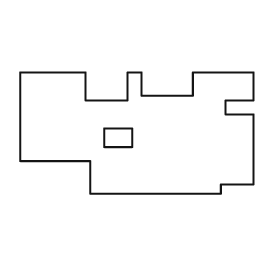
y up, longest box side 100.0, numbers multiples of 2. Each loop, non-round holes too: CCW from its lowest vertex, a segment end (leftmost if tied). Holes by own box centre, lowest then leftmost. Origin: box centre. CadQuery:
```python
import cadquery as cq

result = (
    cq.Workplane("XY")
    .moveTo(-20.0, -26.0)
    .lineTo(36.0, -26.0)
    .lineTo(36.0, -22.0)
    .lineTo(50.0, -22.0)
    .lineTo(50.0, 8.0)
    .lineTo(38.0, 8.0)
    .lineTo(38.0, 14.0)
    .lineTo(50.0, 14.0)
    .lineTo(50.0, 26.0)
    .lineTo(24.0, 26.0)
    .lineTo(24.0, 16.0)
    .lineTo(2.0, 16.0)
    .lineTo(2.0, 26.0)
    .lineTo(-4.0, 26.0)
    .lineTo(-4.0, 14.0)
    .lineTo(-22.0, 14.0)
    .lineTo(-22.0, 26.0)
    .lineTo(-50.0, 26.0)
    .lineTo(-50.0, -12.0)
    .lineTo(-20.0, -12.0)
    .close()
    .moveTo(-14.0, -6.0)
    .lineTo(-2.0, -6.0)
    .lineTo(-2.0, 2.0)
    .lineTo(-14.0, 2.0)
    .close()
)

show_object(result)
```